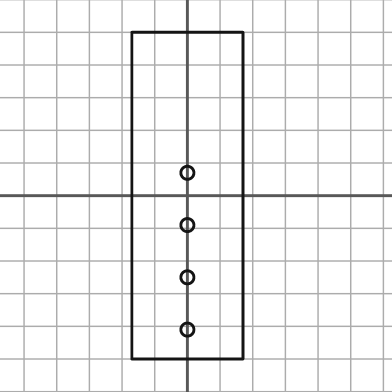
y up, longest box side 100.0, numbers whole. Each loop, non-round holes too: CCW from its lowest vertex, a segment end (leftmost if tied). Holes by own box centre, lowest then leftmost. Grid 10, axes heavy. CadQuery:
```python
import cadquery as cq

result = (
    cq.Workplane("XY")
    .moveTo(-17.0, -50.0)
    .lineTo(17.0, -50.0)
    .lineTo(17.0, 50.0)
    .lineTo(-17.0, 50.0)
    .close()
    .moveTo(0.0, -41.0)
    .circle(2.0)
    .moveTo(0.0, -25.0)
    .circle(2.0)
    .moveTo(0.0, -9.0)
    .circle(2.0)
    .moveTo(0.0, 7.0)
    .circle(2.0)
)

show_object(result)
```